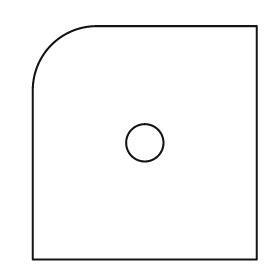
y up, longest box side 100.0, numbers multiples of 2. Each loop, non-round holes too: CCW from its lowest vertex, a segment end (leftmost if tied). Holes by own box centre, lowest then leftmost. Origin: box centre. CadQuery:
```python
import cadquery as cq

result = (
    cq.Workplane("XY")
    .moveTo(-48.0, -50.0)
    .lineTo(48.0, -50.0)
    .lineTo(48.0, 50.0)
    .lineTo(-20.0, 50.0)
    .threePointArc((-40.0, 42.0), (-48.0, 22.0))
    .close()
    .moveTo(0.0, 0.0)
    .circle(8.0)
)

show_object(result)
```